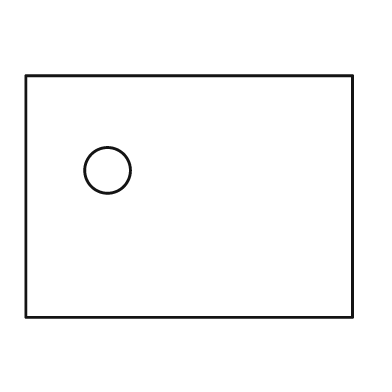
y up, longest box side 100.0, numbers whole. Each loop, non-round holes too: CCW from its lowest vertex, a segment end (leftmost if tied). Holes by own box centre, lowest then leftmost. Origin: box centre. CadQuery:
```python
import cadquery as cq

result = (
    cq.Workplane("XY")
    .moveTo(-50.0, -37.0)
    .lineTo(50.0, -37.0)
    .lineTo(50.0, 37.0)
    .lineTo(-50.0, 37.0)
    .close()
    .moveTo(-25.0, 8.0)
    .circle(7.0)
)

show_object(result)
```